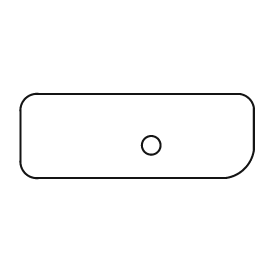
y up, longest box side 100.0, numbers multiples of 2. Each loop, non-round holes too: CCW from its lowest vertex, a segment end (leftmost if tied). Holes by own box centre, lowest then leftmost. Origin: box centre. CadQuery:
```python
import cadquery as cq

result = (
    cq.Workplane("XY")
    .moveTo(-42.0, -18.0)
    .lineTo(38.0, -18.0)
    .threePointArc((46.0, -14.0), (50.0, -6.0))
    .lineTo(50.0, 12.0)
    .threePointArc((48.0, 16.0), (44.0, 18.0))
    .lineTo(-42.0, 18.0)
    .threePointArc((-48.0, 16.0), (-50.0, 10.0))
    .lineTo(-50.0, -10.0)
    .threePointArc((-48.0, -16.0), (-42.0, -18.0))
    .close()
    .moveTo(6.0, -4.0)
    .circle(4.0)
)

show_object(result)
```